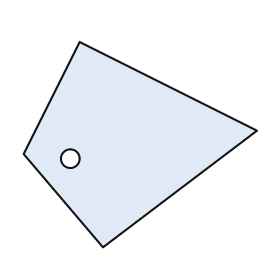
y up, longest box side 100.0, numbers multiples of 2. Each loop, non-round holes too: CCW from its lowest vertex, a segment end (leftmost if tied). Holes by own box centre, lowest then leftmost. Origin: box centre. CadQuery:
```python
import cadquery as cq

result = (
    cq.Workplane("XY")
    .moveTo(-16.0, -44.0)
    .lineTo(50.0, 6.0)
    .lineTo(-26.0, 44.0)
    .lineTo(-50.0, -4.0)
    .close()
    .moveTo(-30.0, -6.0)
    .circle(4.0)
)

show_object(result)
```